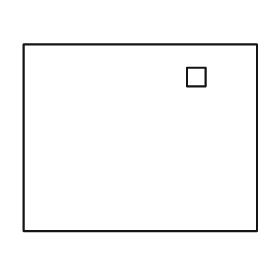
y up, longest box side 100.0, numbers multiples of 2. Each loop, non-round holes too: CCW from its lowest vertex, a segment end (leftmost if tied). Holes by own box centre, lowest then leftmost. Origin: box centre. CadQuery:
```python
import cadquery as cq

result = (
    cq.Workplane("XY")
    .moveTo(-50.0, -40.0)
    .lineTo(50.0, -40.0)
    .lineTo(50.0, 40.0)
    .lineTo(-50.0, 40.0)
    .close()
    .moveTo(20.0, 22.0)
    .lineTo(28.0, 22.0)
    .lineTo(28.0, 30.0)
    .lineTo(20.0, 30.0)
    .close()
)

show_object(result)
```